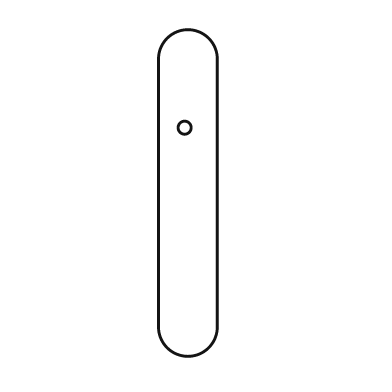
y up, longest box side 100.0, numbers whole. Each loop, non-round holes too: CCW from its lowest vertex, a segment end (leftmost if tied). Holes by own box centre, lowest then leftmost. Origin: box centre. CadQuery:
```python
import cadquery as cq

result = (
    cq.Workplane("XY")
    .moveTo(-9.0, -41.0)
    .threePointArc((0.0, -50.0), (9.0, -41.0))
    .lineTo(9.0, 41.0)
    .threePointArc((0.0, 50.0), (-9.0, 41.0))
    .close()
    .moveTo(-1.0, 20.0)
    .circle(2.0)
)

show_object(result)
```